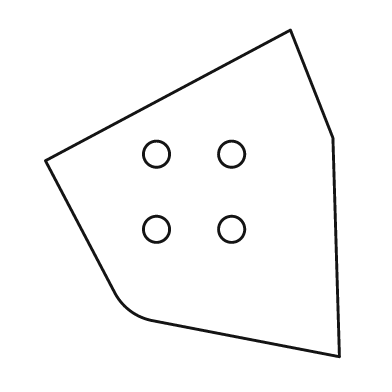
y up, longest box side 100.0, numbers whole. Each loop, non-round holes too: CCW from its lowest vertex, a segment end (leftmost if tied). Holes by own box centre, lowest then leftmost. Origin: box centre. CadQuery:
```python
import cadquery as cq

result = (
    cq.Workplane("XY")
    .moveTo(45.0, -50.0)
    .lineTo(43.0, 17.0)
    .lineTo(30.0, 50.0)
    .lineTo(-45.0, 10.0)
    .lineTo(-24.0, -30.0)
    .threePointArc((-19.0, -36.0), (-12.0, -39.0))
    .close()
    .moveTo(-11.0, -11.0)
    .circle(4.0)
    .moveTo(12.0, -11.0)
    .circle(4.0)
    .moveTo(-11.0, 12.0)
    .circle(4.0)
    .moveTo(12.0, 12.0)
    .circle(4.0)
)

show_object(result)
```